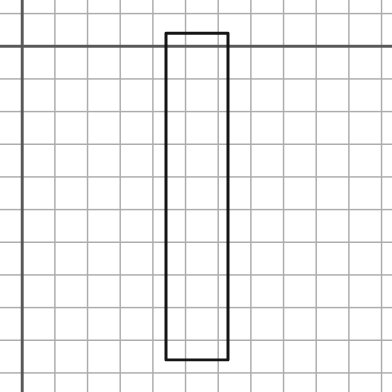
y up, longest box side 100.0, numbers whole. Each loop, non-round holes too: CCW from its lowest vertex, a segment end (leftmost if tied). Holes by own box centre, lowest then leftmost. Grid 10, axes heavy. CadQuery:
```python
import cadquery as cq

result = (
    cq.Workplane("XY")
    .moveTo(44.0, -96.0)
    .lineTo(63.0, -96.0)
    .lineTo(63.0, 4.0)
    .lineTo(44.0, 4.0)
    .close()
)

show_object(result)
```